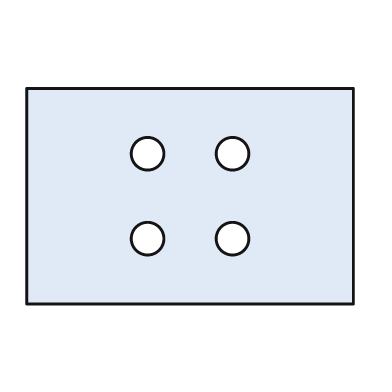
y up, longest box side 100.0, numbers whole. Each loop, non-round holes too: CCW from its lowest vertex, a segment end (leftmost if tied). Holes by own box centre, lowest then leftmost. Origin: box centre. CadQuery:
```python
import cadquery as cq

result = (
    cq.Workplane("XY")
    .moveTo(-50.0, -33.0)
    .lineTo(50.0, -33.0)
    .lineTo(50.0, 33.0)
    .lineTo(-50.0, 33.0)
    .close()
    .moveTo(-13.0, -13.0)
    .circle(5.0)
    .moveTo(13.0, -13.0)
    .circle(5.0)
    .moveTo(-13.0, 13.0)
    .circle(5.0)
    .moveTo(13.0, 13.0)
    .circle(5.0)
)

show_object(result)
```